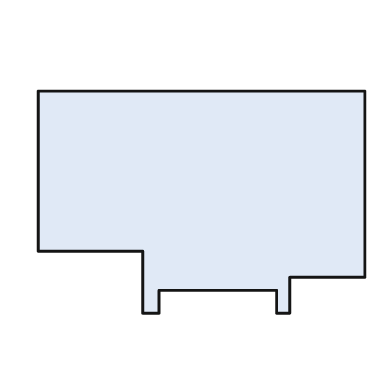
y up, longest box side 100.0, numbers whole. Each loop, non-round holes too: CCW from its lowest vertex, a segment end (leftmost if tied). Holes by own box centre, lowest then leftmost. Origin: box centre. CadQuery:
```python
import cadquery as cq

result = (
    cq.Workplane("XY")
    .moveTo(-18.0, -34.0)
    .lineTo(-13.0, -34.0)
    .lineTo(-13.0, -27.0)
    .lineTo(23.0, -27.0)
    .lineTo(23.0, -34.0)
    .lineTo(27.0, -34.0)
    .lineTo(27.0, -23.0)
    .lineTo(50.0, -23.0)
    .lineTo(50.0, 34.0)
    .lineTo(-50.0, 34.0)
    .lineTo(-50.0, -15.0)
    .lineTo(-18.0, -15.0)
    .close()
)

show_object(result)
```